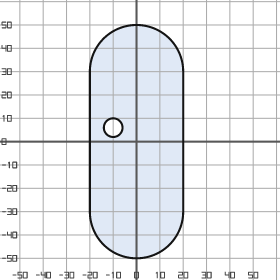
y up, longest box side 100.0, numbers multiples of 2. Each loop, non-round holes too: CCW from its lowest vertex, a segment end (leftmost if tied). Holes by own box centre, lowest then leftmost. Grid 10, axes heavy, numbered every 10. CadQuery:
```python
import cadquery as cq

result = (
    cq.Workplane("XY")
    .moveTo(-20.0, -30.0)
    .threePointArc((0.0, -50.0), (20.0, -30.0))
    .lineTo(20.0, 30.0)
    .threePointArc((0.0, 50.0), (-20.0, 30.0))
    .close()
    .moveTo(-10.0, 6.0)
    .circle(4.0)
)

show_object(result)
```